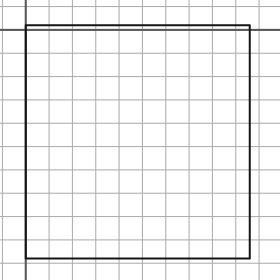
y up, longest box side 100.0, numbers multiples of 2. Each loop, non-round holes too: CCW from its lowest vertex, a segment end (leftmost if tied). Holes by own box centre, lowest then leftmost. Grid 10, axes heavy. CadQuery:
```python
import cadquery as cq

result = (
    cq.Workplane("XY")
    .moveTo(0.0, -98.0)
    .lineTo(96.0, -98.0)
    .lineTo(96.0, 2.0)
    .lineTo(0.0, 2.0)
    .close()
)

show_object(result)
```